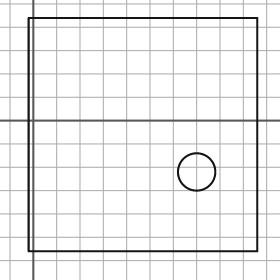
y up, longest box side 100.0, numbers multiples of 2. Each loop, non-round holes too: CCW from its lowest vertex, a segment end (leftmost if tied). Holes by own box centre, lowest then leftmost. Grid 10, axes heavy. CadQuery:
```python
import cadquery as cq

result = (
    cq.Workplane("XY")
    .moveTo(-2.0, -56.0)
    .lineTo(96.0, -56.0)
    .lineTo(96.0, 44.0)
    .lineTo(-2.0, 44.0)
    .close()
    .moveTo(70.0, -22.0)
    .circle(8.0)
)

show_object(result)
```